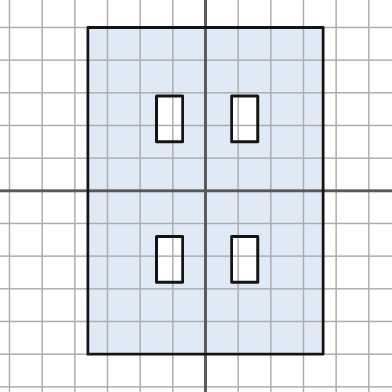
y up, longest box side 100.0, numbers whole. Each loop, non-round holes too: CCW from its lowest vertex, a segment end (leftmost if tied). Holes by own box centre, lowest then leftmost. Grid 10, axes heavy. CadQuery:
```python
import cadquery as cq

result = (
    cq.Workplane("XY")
    .moveTo(-36.0, -50.0)
    .lineTo(36.0, -50.0)
    .lineTo(36.0, 50.0)
    .lineTo(-36.0, 50.0)
    .close()
    .moveTo(-15.0, -28.0)
    .lineTo(-7.0, -28.0)
    .lineTo(-7.0, -14.0)
    .lineTo(-15.0, -14.0)
    .close()
    .moveTo(8.0, -28.0)
    .lineTo(16.0, -28.0)
    .lineTo(16.0, -14.0)
    .lineTo(8.0, -14.0)
    .close()
    .moveTo(-15.0, 15.0)
    .lineTo(-7.0, 15.0)
    .lineTo(-7.0, 29.0)
    .lineTo(-15.0, 29.0)
    .close()
    .moveTo(8.0, 15.0)
    .lineTo(16.0, 15.0)
    .lineTo(16.0, 29.0)
    .lineTo(8.0, 29.0)
    .close()
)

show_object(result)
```